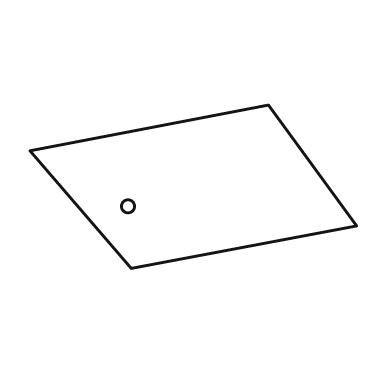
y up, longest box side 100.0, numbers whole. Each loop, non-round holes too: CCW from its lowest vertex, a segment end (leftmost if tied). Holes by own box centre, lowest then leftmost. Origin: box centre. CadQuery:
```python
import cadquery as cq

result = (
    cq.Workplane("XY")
    .moveTo(-19.0, -25.0)
    .lineTo(50.0, -12.0)
    .lineTo(23.0, 25.0)
    .lineTo(-50.0, 11.0)
    .close()
    .moveTo(-20.0, -6.0)
    .circle(2.0)
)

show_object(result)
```